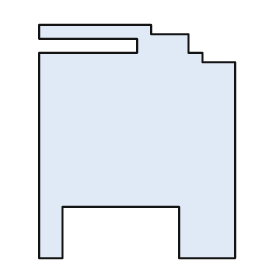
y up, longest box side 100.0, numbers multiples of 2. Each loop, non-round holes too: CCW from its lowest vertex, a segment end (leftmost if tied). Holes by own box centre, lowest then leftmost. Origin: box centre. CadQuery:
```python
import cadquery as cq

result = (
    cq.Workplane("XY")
    .moveTo(-42.0, -50.0)
    .lineTo(-32.0, -50.0)
    .lineTo(-32.0, -28.0)
    .lineTo(18.0, -28.0)
    .lineTo(18.0, -50.0)
    .lineTo(42.0, -50.0)
    .lineTo(42.0, 34.0)
    .lineTo(28.0, 34.0)
    .lineTo(28.0, 38.0)
    .lineTo(22.0, 38.0)
    .lineTo(22.0, 46.0)
    .lineTo(6.0, 46.0)
    .lineTo(6.0, 50.0)
    .lineTo(-42.0, 50.0)
    .lineTo(-42.0, 44.0)
    .lineTo(0.0, 44.0)
    .lineTo(0.0, 38.0)
    .lineTo(-42.0, 38.0)
    .close()
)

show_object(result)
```